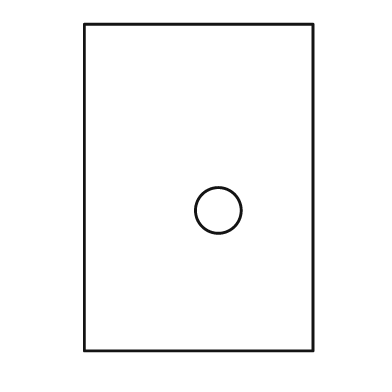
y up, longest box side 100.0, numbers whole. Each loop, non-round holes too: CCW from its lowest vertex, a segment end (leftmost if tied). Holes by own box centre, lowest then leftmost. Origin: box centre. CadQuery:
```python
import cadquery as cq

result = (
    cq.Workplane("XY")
    .moveTo(-35.0, -50.0)
    .lineTo(35.0, -50.0)
    .lineTo(35.0, 50.0)
    .lineTo(-35.0, 50.0)
    .close()
    .moveTo(6.0, -7.0)
    .circle(7.0)
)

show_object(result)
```